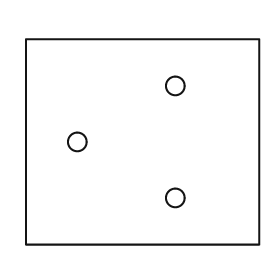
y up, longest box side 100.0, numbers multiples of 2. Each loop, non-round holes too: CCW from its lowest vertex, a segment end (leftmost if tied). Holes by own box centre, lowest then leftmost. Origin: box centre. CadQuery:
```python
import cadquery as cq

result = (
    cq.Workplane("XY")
    .moveTo(-50.0, -44.0)
    .lineTo(50.0, -44.0)
    .lineTo(50.0, 44.0)
    .lineTo(-50.0, 44.0)
    .close()
    .moveTo(14.0, -24.0)
    .circle(4.0)
    .moveTo(-28.0, 0.0)
    .circle(4.0)
    .moveTo(14.0, 24.0)
    .circle(4.0)
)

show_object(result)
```